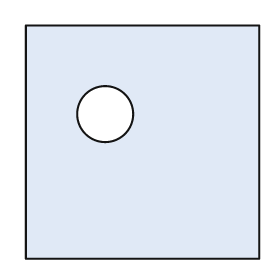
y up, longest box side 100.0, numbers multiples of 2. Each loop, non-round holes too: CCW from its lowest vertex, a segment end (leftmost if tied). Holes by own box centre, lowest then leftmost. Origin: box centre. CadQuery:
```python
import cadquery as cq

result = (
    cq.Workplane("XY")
    .moveTo(-50.0, -50.0)
    .lineTo(50.0, -50.0)
    .lineTo(50.0, 50.0)
    .lineTo(-50.0, 50.0)
    .close()
    .moveTo(-16.0, 12.0)
    .circle(12.0)
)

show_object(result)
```